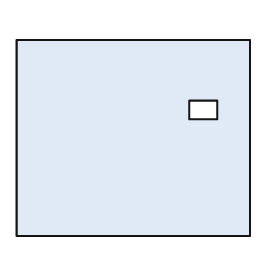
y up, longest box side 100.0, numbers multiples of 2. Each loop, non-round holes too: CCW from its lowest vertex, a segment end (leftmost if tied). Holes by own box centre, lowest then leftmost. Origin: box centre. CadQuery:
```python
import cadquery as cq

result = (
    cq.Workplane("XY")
    .moveTo(-50.0, -42.0)
    .lineTo(50.0, -42.0)
    .lineTo(50.0, 42.0)
    .lineTo(-50.0, 42.0)
    .close()
    .moveTo(24.0, 8.0)
    .lineTo(36.0, 8.0)
    .lineTo(36.0, 16.0)
    .lineTo(24.0, 16.0)
    .close()
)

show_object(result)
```